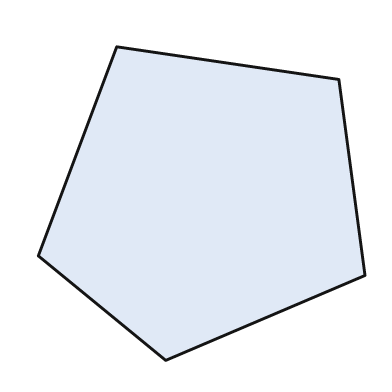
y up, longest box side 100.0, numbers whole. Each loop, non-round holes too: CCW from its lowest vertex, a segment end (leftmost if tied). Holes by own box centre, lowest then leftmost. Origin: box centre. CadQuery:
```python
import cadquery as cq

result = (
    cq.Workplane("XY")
    .moveTo(-11.0, -48.0)
    .lineTo(50.0, -22.0)
    .lineTo(42.0, 38.0)
    .lineTo(-26.0, 48.0)
    .lineTo(-50.0, -16.0)
    .close()
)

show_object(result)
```